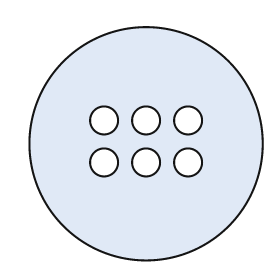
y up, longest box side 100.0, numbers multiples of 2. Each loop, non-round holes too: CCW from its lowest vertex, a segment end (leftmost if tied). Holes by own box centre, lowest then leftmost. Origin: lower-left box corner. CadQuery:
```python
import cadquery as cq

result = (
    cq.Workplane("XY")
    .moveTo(50.0, 50.0)
    .circle(50.0)
    .moveTo(32.0, 42.0)
    .circle(6.0)
    .moveTo(50.0, 42.0)
    .circle(6.0)
    .moveTo(68.0, 42.0)
    .circle(6.0)
    .moveTo(32.0, 60.0)
    .circle(6.0)
    .moveTo(50.0, 60.0)
    .circle(6.0)
    .moveTo(68.0, 60.0)
    .circle(6.0)
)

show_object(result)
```